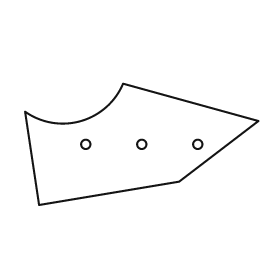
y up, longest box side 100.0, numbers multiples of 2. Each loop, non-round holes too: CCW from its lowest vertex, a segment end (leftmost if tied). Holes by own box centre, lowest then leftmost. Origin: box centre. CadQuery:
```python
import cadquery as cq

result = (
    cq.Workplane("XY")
    .moveTo(-44.0, -26.0)
    .lineTo(16.0, -16.0)
    .lineTo(50.0, 10.0)
    .lineTo(-8.0, 26.0)
    .threePointArc((-26.0, 10.0), (-50.0, 14.0))
    .close()
    .moveTo(-24.0, 0.0)
    .circle(2.0)
    .moveTo(0.0, 0.0)
    .circle(2.0)
    .moveTo(24.0, 0.0)
    .circle(2.0)
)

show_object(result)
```